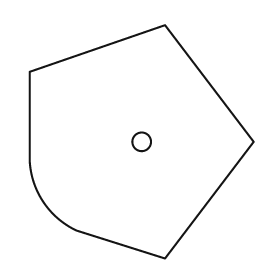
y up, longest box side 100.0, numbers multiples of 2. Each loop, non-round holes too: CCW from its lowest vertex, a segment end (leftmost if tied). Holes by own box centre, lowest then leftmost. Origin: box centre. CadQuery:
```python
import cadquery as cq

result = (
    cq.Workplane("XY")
    .moveTo(10.0, -50.0)
    .lineTo(48.0, 0.0)
    .lineTo(10.0, 50.0)
    .lineTo(-48.0, 30.0)
    .lineTo(-48.0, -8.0)
    .threePointArc((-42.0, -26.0), (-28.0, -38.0))
    .close()
    .moveTo(0.0, 0.0)
    .circle(4.0)
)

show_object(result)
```